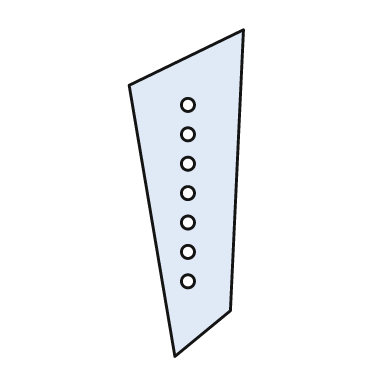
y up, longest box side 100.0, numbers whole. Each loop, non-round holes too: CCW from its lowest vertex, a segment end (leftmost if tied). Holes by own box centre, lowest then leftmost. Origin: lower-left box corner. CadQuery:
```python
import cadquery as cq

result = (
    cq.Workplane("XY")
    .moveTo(14.0, 0.0)
    .lineTo(31.0, 14.0)
    .lineTo(35.0, 100.0)
    .lineTo(0.0, 83.0)
    .close()
    .moveTo(18.0, 23.0)
    .circle(2.0)
    .moveTo(18.0, 32.0)
    .circle(2.0)
    .moveTo(18.0, 41.0)
    .circle(2.0)
    .moveTo(18.0, 50.0)
    .circle(2.0)
    .moveTo(18.0, 59.0)
    .circle(2.0)
    .moveTo(18.0, 68.0)
    .circle(2.0)
    .moveTo(18.0, 77.0)
    .circle(2.0)
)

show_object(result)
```